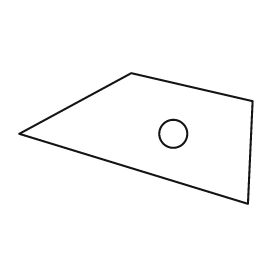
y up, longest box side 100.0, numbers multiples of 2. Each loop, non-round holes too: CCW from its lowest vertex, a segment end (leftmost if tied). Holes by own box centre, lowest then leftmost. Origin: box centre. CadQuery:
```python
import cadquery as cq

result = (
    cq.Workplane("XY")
    .moveTo(48.0, -28.0)
    .lineTo(50.0, 16.0)
    .lineTo(-2.0, 28.0)
    .lineTo(-50.0, 2.0)
    .close()
    .moveTo(16.0, 2.0)
    .circle(6.0)
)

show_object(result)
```